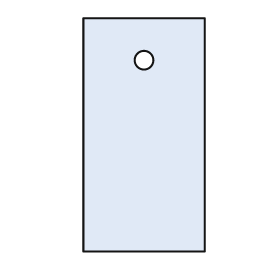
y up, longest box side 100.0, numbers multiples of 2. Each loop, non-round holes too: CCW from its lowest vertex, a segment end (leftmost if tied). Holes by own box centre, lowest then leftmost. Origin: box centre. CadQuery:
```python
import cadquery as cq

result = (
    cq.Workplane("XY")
    .moveTo(-26.0, -50.0)
    .lineTo(26.0, -50.0)
    .lineTo(26.0, 50.0)
    .lineTo(-26.0, 50.0)
    .close()
    .moveTo(0.0, 32.0)
    .circle(4.0)
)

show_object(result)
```